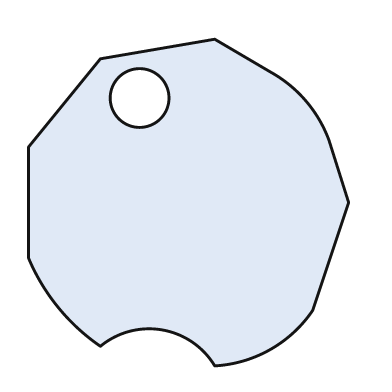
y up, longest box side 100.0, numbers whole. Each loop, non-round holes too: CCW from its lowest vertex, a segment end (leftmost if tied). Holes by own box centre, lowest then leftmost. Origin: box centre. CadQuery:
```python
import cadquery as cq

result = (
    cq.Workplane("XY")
    .moveTo(8.0, -50.0)
    .threePointArc((25.0, -45.0), (38.0, -33.0))
    .lineTo(49.0, 0.0)
    .lineTo(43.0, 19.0)
    .threePointArc((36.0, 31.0), (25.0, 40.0))
    .lineTo(8.0, 50.0)
    .lineTo(-27.0, 44.0)
    .lineTo(-49.0, 17.0)
    .lineTo(-49.0, -17.0)
    .threePointArc((-40.0, -32.0), (-27.0, -44.0))
    .threePointArc((-8.0, -39.0), (8.0, -50.0))
    .close()
    .moveTo(-15.0, 32.0)
    .circle(9.0)
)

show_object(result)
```